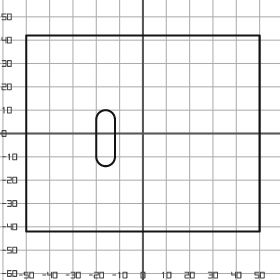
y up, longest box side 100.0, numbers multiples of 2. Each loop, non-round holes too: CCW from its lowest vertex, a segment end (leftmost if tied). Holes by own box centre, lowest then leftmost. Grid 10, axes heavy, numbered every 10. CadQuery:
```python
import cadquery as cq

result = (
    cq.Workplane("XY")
    .moveTo(-50.0, -42.0)
    .lineTo(50.0, -42.0)
    .lineTo(50.0, 42.0)
    .lineTo(-50.0, 42.0)
    .close()
    .moveTo(-20.0, -10.0)
    .threePointArc((-16.0, -14.0), (-12.0, -10.0))
    .lineTo(-12.0, 6.0)
    .threePointArc((-16.0, 10.0), (-20.0, 6.0))
    .close()
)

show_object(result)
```